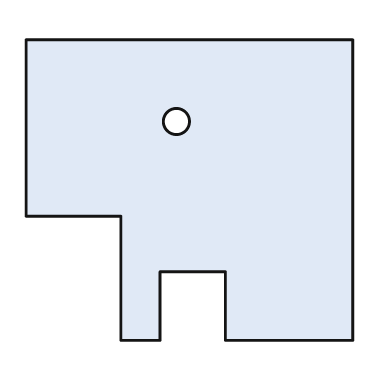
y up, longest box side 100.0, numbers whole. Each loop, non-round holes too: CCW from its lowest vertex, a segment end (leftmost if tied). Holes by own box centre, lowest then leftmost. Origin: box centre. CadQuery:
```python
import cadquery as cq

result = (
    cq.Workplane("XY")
    .moveTo(-21.0, -46.0)
    .lineTo(-9.0, -46.0)
    .lineTo(-9.0, -25.0)
    .lineTo(11.0, -25.0)
    .lineTo(11.0, -46.0)
    .lineTo(50.0, -46.0)
    .lineTo(50.0, 46.0)
    .lineTo(-50.0, 46.0)
    .lineTo(-50.0, -8.0)
    .lineTo(-21.0, -8.0)
    .close()
    .moveTo(-4.0, 21.0)
    .circle(4.0)
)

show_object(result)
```